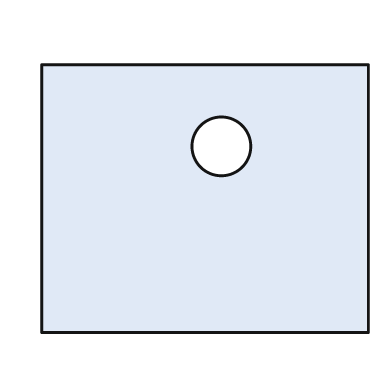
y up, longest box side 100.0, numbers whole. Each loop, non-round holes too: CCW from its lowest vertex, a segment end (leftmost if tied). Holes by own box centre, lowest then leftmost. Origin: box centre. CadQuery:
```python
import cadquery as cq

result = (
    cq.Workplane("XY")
    .moveTo(-50.0, -41.0)
    .lineTo(50.0, -41.0)
    .lineTo(50.0, 41.0)
    .lineTo(-50.0, 41.0)
    .close()
    .moveTo(5.0, 16.0)
    .circle(9.0)
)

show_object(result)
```